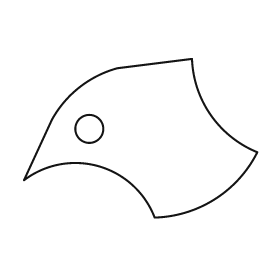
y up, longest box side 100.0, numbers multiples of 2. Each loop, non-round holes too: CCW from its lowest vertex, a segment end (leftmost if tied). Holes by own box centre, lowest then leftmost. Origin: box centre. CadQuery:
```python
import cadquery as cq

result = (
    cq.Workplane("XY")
    .moveTo(6.0, -34.0)
    .threePointArc((32.0, -26.0), (50.0, -6.0))
    .threePointArc((30.0, 10.0), (22.0, 34.0))
    .lineTo(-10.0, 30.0)
    .threePointArc((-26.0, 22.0), (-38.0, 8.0))
    .lineTo(-50.0, -18.0)
    .threePointArc((-18.0, -12.0), (6.0, -34.0))
    .close()
    .moveTo(-22.0, 4.0)
    .circle(6.0)
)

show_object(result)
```